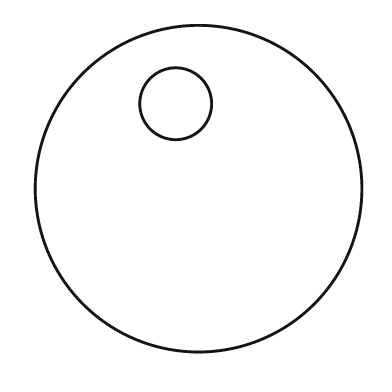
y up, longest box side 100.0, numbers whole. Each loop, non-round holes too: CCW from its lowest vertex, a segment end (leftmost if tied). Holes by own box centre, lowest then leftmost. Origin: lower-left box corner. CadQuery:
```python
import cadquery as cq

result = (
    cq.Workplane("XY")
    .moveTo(50.0, 50.0)
    .circle(50.0)
    .moveTo(43.0, 76.0)
    .circle(11.0)
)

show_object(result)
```